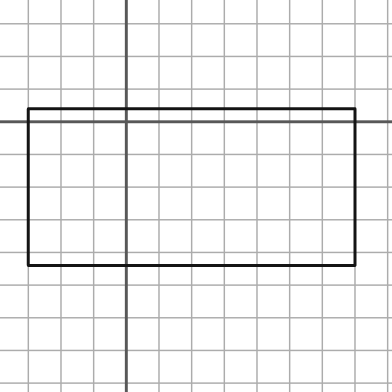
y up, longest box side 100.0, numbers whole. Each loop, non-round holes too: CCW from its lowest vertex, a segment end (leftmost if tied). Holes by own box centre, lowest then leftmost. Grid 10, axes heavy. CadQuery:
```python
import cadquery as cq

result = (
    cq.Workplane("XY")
    .moveTo(-30.0, -44.0)
    .lineTo(70.0, -44.0)
    .lineTo(70.0, 4.0)
    .lineTo(-30.0, 4.0)
    .close()
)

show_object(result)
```